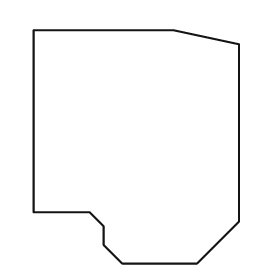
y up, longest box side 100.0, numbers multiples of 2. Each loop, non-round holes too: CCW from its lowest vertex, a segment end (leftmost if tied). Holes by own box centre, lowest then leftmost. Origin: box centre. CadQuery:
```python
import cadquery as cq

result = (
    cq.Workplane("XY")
    .moveTo(-6.0, -50.0)
    .lineTo(26.0, -50.0)
    .lineTo(44.0, -32.0)
    .lineTo(44.0, 44.0)
    .lineTo(16.0, 50.0)
    .lineTo(-44.0, 50.0)
    .lineTo(-44.0, -28.0)
    .lineTo(-20.0, -28.0)
    .lineTo(-14.0, -34.0)
    .lineTo(-14.0, -42.0)
    .close()
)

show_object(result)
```